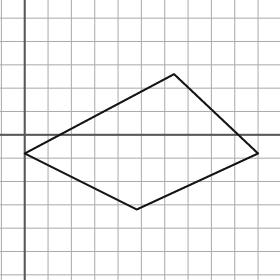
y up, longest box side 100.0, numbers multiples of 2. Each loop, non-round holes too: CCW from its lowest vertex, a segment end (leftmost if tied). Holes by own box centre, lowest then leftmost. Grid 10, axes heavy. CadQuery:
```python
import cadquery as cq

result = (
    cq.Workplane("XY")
    .moveTo(48.0, -32.0)
    .lineTo(100.0, -8.0)
    .lineTo(64.0, 26.0)
    .lineTo(0.0, -8.0)
    .close()
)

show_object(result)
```